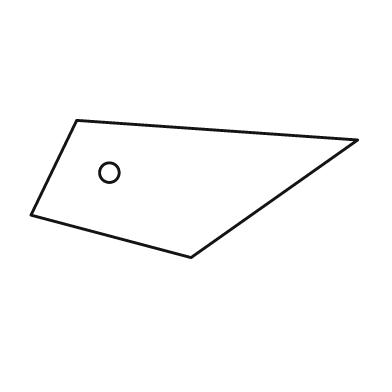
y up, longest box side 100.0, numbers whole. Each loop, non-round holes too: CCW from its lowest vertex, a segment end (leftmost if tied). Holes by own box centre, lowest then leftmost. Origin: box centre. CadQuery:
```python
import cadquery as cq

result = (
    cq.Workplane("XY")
    .moveTo(-1.0, -21.0)
    .lineTo(50.0, 15.0)
    .lineTo(-36.0, 21.0)
    .lineTo(-50.0, -8.0)
    .close()
    .moveTo(-26.0, 5.0)
    .circle(3.0)
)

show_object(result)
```